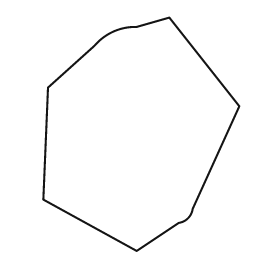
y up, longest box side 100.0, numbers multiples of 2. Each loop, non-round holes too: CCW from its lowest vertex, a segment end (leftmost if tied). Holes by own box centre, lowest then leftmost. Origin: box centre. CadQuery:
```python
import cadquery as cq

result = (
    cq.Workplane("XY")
    .moveTo(-2.0, -50.0)
    .lineTo(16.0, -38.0)
    .threePointArc((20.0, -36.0), (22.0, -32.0))
    .lineTo(42.0, 12.0)
    .lineTo(12.0, 50.0)
    .lineTo(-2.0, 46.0)
    .threePointArc((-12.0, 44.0), (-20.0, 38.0))
    .lineTo(-40.0, 20.0)
    .lineTo(-42.0, -28.0)
    .close()
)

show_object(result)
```